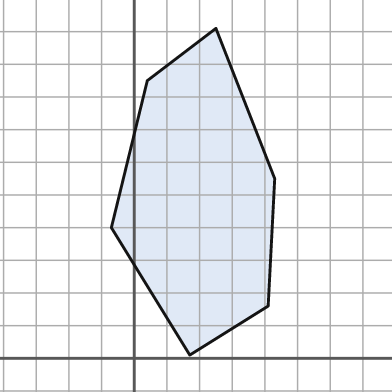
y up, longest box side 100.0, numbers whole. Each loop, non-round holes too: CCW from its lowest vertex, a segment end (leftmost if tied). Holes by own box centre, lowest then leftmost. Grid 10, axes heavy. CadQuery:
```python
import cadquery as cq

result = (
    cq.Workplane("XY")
    .moveTo(17.0, 1.0)
    .lineTo(41.0, 16.0)
    .lineTo(43.0, 55.0)
    .lineTo(25.0, 101.0)
    .lineTo(4.0, 85.0)
    .lineTo(-7.0, 40.0)
    .close()
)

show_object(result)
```